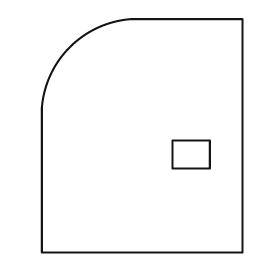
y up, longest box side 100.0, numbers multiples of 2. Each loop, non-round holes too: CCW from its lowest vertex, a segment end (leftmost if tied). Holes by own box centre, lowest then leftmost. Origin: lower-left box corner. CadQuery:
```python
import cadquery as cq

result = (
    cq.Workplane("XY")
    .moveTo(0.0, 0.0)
    .lineTo(86.0, 0.0)
    .lineTo(86.0, 100.0)
    .lineTo(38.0, 100.0)
    .threePointArc((12.0, 88.0), (0.0, 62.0))
    .close()
    .moveTo(56.0, 36.0)
    .lineTo(72.0, 36.0)
    .lineTo(72.0, 48.0)
    .lineTo(56.0, 48.0)
    .close()
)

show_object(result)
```